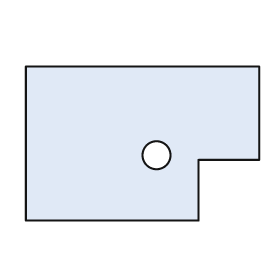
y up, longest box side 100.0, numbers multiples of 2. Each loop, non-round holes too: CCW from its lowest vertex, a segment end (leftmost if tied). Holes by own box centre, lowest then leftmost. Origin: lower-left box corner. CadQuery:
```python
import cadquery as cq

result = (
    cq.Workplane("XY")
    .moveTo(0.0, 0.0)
    .lineTo(74.0, 0.0)
    .lineTo(74.0, 26.0)
    .lineTo(100.0, 26.0)
    .lineTo(100.0, 66.0)
    .lineTo(0.0, 66.0)
    .close()
    .moveTo(56.0, 28.0)
    .circle(6.0)
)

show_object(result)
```